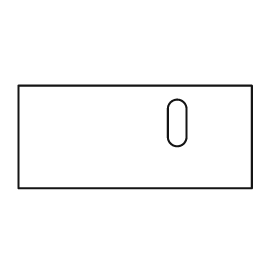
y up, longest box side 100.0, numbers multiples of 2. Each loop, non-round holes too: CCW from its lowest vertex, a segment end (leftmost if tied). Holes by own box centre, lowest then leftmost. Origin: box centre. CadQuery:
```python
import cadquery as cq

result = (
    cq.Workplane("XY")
    .moveTo(-50.0, -22.0)
    .lineTo(50.0, -22.0)
    .lineTo(50.0, 22.0)
    .lineTo(-50.0, 22.0)
    .close()
    .moveTo(14.0, 0.0)
    .threePointArc((18.0, -4.0), (22.0, 0.0))
    .lineTo(22.0, 12.0)
    .threePointArc((18.0, 16.0), (14.0, 12.0))
    .close()
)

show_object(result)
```